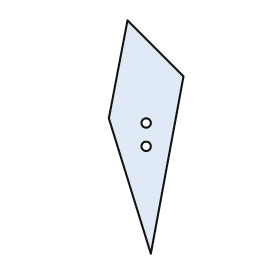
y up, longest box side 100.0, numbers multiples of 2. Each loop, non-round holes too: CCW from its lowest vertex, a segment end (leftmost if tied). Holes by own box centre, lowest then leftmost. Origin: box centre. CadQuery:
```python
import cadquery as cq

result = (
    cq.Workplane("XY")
    .moveTo(2.0, -50.0)
    .lineTo(16.0, 26.0)
    .lineTo(-8.0, 50.0)
    .lineTo(-16.0, 8.0)
    .close()
    .moveTo(0.0, -4.0)
    .circle(2.0)
    .moveTo(0.0, 6.0)
    .circle(2.0)
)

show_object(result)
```